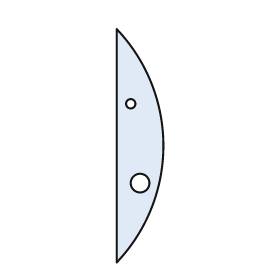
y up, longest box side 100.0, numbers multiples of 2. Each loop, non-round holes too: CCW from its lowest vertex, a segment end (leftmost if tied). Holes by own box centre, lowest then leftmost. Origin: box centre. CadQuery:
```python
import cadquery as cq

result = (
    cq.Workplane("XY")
    .moveTo(-10.0, -50.0)
    .threePointArc((10.0, 0.0), (-10.0, 50.0))
    .close()
    .moveTo(0.0, -16.0)
    .circle(4.0)
    .moveTo(-4.0, 18.0)
    .circle(2.0)
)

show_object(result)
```